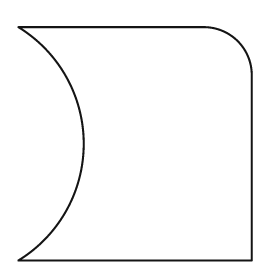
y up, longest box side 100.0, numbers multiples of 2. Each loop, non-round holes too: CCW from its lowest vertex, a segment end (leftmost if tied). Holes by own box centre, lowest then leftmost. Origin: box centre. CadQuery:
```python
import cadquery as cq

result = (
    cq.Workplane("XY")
    .moveTo(-50.0, -50.0)
    .lineTo(50.0, -50.0)
    .lineTo(50.0, 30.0)
    .threePointArc((44.0, 44.0), (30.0, 50.0))
    .lineTo(-50.0, 50.0)
    .threePointArc((-22.0, 0.0), (-50.0, -50.0))
    .close()
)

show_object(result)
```